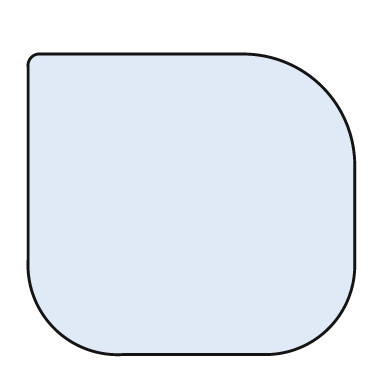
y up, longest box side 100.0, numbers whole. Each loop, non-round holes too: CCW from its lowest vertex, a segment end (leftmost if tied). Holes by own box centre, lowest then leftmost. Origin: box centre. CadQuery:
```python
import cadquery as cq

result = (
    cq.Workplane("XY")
    .moveTo(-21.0, -46.0)
    .lineTo(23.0, -46.0)
    .threePointArc((42.0, -38.0), (50.0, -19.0))
    .lineTo(50.0, 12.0)
    .threePointArc((40.0, 36.0), (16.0, 46.0))
    .lineTo(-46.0, 46.0)
    .threePointArc((-49.0, 45.0), (-50.0, 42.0))
    .lineTo(-50.0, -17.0)
    .threePointArc((-42.0, -38.0), (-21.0, -46.0))
    .close()
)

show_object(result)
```